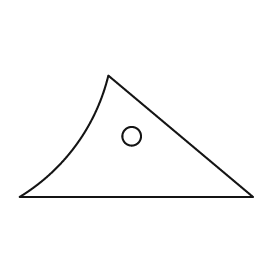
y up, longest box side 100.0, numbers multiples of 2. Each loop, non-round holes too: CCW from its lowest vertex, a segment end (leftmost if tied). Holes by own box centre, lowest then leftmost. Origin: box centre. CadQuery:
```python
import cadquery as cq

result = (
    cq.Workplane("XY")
    .moveTo(-50.0, -26.0)
    .lineTo(50.0, -26.0)
    .lineTo(-12.0, 26.0)
    .threePointArc((-26.0, -4.0), (-50.0, -26.0))
    .close()
    .moveTo(-2.0, 0.0)
    .circle(4.0)
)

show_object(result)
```